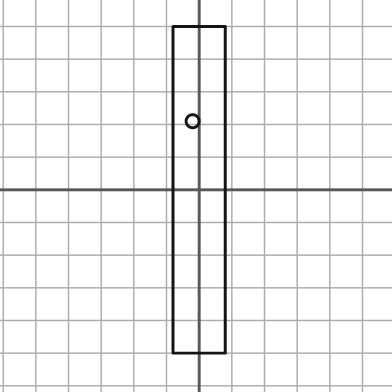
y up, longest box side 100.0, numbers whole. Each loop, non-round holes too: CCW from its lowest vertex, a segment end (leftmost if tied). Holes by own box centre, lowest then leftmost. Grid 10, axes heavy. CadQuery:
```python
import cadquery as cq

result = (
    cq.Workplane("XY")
    .moveTo(-8.0, -50.0)
    .lineTo(8.0, -50.0)
    .lineTo(8.0, 50.0)
    .lineTo(-8.0, 50.0)
    .close()
    .moveTo(-2.0, 21.0)
    .circle(2.0)
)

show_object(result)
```